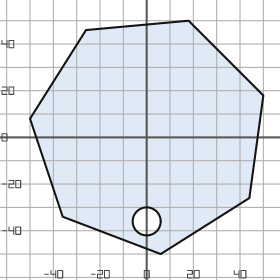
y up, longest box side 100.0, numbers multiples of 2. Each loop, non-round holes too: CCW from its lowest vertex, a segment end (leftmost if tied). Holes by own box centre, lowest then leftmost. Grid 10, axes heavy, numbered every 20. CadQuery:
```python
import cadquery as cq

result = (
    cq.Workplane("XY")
    .moveTo(6.0, -50.0)
    .lineTo(44.0, -26.0)
    .lineTo(50.0, 18.0)
    .lineTo(18.0, 50.0)
    .lineTo(-26.0, 46.0)
    .lineTo(-50.0, 8.0)
    .lineTo(-36.0, -34.0)
    .close()
    .moveTo(0.0, -36.0)
    .circle(6.0)
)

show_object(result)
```